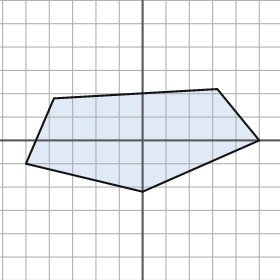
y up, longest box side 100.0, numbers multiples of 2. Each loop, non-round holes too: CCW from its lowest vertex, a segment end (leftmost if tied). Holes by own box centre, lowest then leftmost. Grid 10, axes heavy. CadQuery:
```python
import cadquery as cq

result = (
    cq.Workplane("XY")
    .moveTo(0.0, -22.0)
    .lineTo(50.0, 0.0)
    .lineTo(32.0, 22.0)
    .lineTo(-38.0, 18.0)
    .lineTo(-50.0, -10.0)
    .close()
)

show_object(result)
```